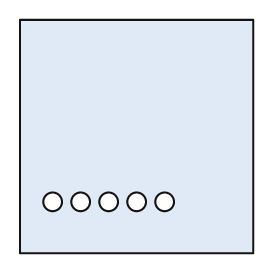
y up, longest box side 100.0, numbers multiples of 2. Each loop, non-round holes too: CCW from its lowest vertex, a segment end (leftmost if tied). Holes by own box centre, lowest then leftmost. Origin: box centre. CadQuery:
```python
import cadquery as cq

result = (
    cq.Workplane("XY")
    .moveTo(-50.0, -50.0)
    .lineTo(50.0, -50.0)
    .lineTo(50.0, 50.0)
    .lineTo(-50.0, 50.0)
    .close()
    .moveTo(-36.0, -28.0)
    .circle(4.0)
    .moveTo(-24.0, -28.0)
    .circle(4.0)
    .moveTo(-12.0, -28.0)
    .circle(4.0)
    .moveTo(0.0, -28.0)
    .circle(4.0)
    .moveTo(12.0, -28.0)
    .circle(4.0)
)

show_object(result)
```